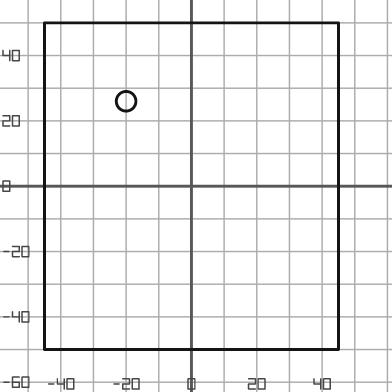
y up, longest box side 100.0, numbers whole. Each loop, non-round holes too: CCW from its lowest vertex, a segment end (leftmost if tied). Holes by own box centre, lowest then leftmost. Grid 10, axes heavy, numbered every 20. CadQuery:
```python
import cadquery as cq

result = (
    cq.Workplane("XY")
    .moveTo(-45.0, -50.0)
    .lineTo(45.0, -50.0)
    .lineTo(45.0, 50.0)
    .lineTo(-45.0, 50.0)
    .close()
    .moveTo(-20.0, 26.0)
    .circle(3.0)
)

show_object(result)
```